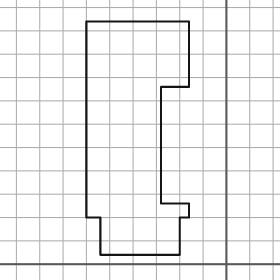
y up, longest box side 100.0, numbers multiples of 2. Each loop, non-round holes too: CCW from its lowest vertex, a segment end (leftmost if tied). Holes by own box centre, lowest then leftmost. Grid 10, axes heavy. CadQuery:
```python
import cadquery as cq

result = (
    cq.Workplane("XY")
    .moveTo(-54.0, 4.0)
    .lineTo(-20.0, 4.0)
    .lineTo(-20.0, 20.0)
    .lineTo(-16.0, 20.0)
    .lineTo(-16.0, 26.0)
    .lineTo(-28.0, 26.0)
    .lineTo(-28.0, 76.0)
    .lineTo(-16.0, 76.0)
    .lineTo(-16.0, 104.0)
    .lineTo(-60.0, 104.0)
    .lineTo(-60.0, 20.0)
    .lineTo(-54.0, 20.0)
    .close()
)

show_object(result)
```